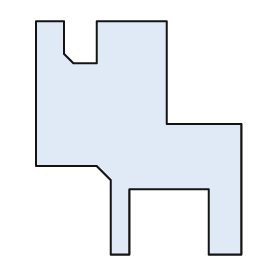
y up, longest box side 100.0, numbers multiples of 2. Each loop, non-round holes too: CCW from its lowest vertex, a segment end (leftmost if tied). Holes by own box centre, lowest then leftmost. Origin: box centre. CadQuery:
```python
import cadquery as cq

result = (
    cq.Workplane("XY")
    .moveTo(-12.0, -50.0)
    .lineTo(-4.0, -50.0)
    .lineTo(-4.0, -22.0)
    .lineTo(30.0, -22.0)
    .lineTo(30.0, -50.0)
    .lineTo(44.0, -50.0)
    .lineTo(44.0, 6.0)
    .lineTo(12.0, 6.0)
    .lineTo(12.0, 50.0)
    .lineTo(-18.0, 50.0)
    .lineTo(-18.0, 32.0)
    .lineTo(-28.0, 32.0)
    .lineTo(-32.0, 36.0)
    .lineTo(-32.0, 50.0)
    .lineTo(-44.0, 50.0)
    .lineTo(-44.0, -12.0)
    .lineTo(-18.0, -12.0)
    .lineTo(-12.0, -18.0)
    .close()
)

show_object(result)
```